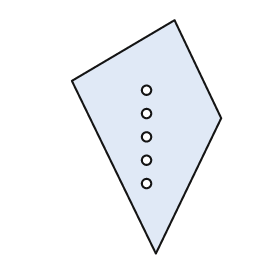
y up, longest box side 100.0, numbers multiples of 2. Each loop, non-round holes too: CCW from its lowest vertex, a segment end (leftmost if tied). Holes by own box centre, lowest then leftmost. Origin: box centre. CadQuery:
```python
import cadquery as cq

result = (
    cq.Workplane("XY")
    .moveTo(4.0, -50.0)
    .lineTo(32.0, 8.0)
    .lineTo(12.0, 50.0)
    .lineTo(-32.0, 24.0)
    .close()
    .moveTo(0.0, -20.0)
    .circle(2.0)
    .moveTo(0.0, -10.0)
    .circle(2.0)
    .moveTo(0.0, 0.0)
    .circle(2.0)
    .moveTo(0.0, 10.0)
    .circle(2.0)
    .moveTo(0.0, 20.0)
    .circle(2.0)
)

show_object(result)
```